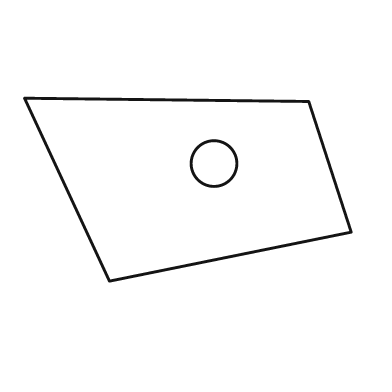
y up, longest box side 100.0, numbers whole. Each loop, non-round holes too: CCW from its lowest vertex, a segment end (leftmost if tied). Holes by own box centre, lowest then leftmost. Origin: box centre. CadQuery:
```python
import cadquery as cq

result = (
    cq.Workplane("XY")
    .moveTo(-24.0, -28.0)
    .lineTo(50.0, -13.0)
    .lineTo(37.0, 27.0)
    .lineTo(-50.0, 28.0)
    .close()
    .moveTo(8.0, 8.0)
    .circle(7.0)
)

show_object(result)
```